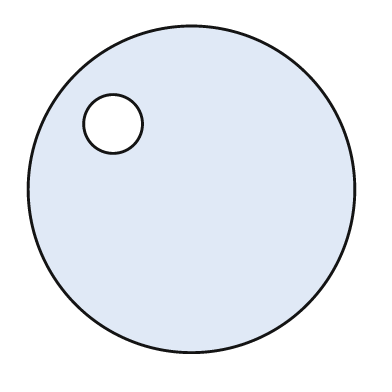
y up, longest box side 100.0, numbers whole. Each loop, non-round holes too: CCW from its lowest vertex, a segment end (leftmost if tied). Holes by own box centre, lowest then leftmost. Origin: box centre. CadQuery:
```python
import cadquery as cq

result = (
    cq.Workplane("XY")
    .moveTo(0.0, 0.0)
    .circle(50.0)
    .moveTo(-24.0, 20.0)
    .circle(9.0)
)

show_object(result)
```